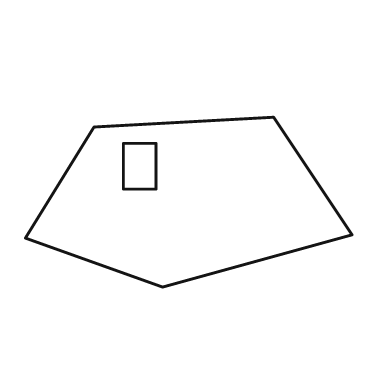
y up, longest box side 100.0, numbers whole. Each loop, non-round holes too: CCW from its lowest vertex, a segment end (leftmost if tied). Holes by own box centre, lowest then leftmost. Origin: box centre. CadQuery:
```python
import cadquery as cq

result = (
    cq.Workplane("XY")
    .moveTo(-8.0, -26.0)
    .lineTo(50.0, -10.0)
    .lineTo(26.0, 26.0)
    .lineTo(-29.0, 23.0)
    .lineTo(-50.0, -11.0)
    .close()
    .moveTo(-20.0, 4.0)
    .lineTo(-10.0, 4.0)
    .lineTo(-10.0, 18.0)
    .lineTo(-20.0, 18.0)
    .close()
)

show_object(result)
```